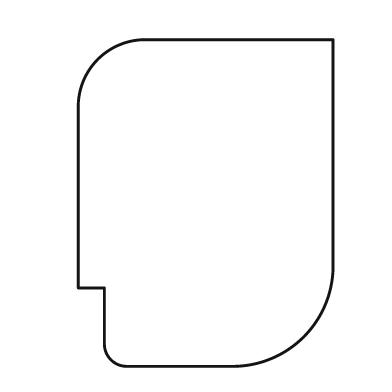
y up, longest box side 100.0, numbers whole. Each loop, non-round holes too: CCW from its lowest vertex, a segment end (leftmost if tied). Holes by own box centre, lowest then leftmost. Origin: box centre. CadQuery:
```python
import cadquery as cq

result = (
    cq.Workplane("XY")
    .moveTo(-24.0, -50.0)
    .lineTo(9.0, -50.0)
    .threePointArc((30.0, -41.0), (39.0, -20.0))
    .lineTo(39.0, 50.0)
    .lineTo(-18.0, 50.0)
    .threePointArc((-33.0, 44.0), (-39.0, 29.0))
    .lineTo(-39.0, -26.0)
    .lineTo(-31.0, -26.0)
    .lineTo(-31.0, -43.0)
    .threePointArc((-29.0, -48.0), (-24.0, -50.0))
    .close()
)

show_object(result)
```